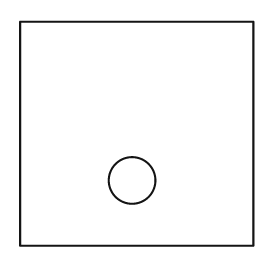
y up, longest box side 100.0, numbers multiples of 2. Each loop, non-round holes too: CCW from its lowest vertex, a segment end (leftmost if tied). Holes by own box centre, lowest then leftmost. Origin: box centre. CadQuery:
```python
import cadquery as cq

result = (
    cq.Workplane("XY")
    .moveTo(-50.0, -48.0)
    .lineTo(50.0, -48.0)
    .lineTo(50.0, 48.0)
    .lineTo(-50.0, 48.0)
    .close()
    .moveTo(-2.0, -20.0)
    .circle(10.0)
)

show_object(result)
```